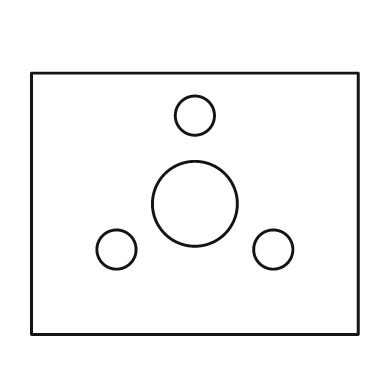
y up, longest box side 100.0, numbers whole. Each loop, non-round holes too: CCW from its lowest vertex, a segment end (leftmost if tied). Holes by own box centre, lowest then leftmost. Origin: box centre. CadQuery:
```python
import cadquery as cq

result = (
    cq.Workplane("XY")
    .moveTo(-50.0, -40.0)
    .lineTo(50.0, -40.0)
    .lineTo(50.0, 40.0)
    .lineTo(-50.0, 40.0)
    .close()
    .moveTo(-24.0, -14.0)
    .circle(6.0)
    .moveTo(24.0, -14.0)
    .circle(6.0)
    .moveTo(0.0, 0.0)
    .circle(13.0)
    .moveTo(0.0, 27.0)
    .circle(6.0)
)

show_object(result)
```